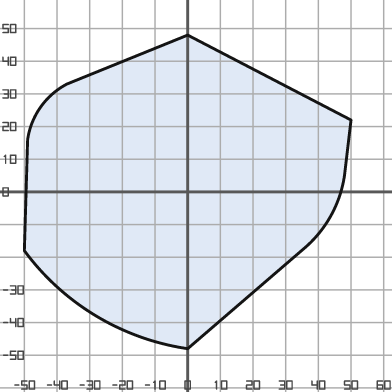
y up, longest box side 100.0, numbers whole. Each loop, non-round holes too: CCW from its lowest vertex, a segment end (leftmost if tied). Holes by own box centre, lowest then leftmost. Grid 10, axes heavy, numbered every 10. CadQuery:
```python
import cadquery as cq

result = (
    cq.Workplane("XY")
    .moveTo(0.0, -48.0)
    .lineTo(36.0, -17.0)
    .threePointArc((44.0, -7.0), (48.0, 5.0))
    .lineTo(50.0, 22.0)
    .lineTo(0.0, 48.0)
    .lineTo(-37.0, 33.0)
    .threePointArc((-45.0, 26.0), (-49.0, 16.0))
    .lineTo(-50.0, -18.0)
    .threePointArc((-28.0, -38.0), (0.0, -48.0))
    .close()
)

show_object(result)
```